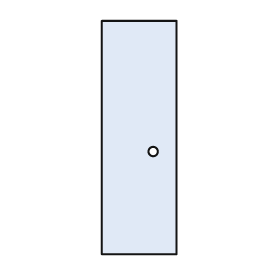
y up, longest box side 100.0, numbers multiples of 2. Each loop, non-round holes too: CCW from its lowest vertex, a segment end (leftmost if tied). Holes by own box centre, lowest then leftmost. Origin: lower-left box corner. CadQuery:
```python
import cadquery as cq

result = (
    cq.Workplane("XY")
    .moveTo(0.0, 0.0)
    .lineTo(32.0, 0.0)
    .lineTo(32.0, 100.0)
    .lineTo(0.0, 100.0)
    .close()
    .moveTo(22.0, 44.0)
    .circle(2.0)
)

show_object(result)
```